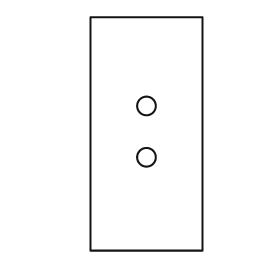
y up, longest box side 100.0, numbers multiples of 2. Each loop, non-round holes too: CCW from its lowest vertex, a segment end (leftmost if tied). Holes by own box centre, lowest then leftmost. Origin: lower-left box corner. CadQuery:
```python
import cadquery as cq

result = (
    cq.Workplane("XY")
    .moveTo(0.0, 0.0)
    .lineTo(48.0, 0.0)
    .lineTo(48.0, 100.0)
    .lineTo(0.0, 100.0)
    .close()
    .moveTo(24.0, 40.0)
    .circle(4.0)
    .moveTo(24.0, 62.0)
    .circle(4.0)
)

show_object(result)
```